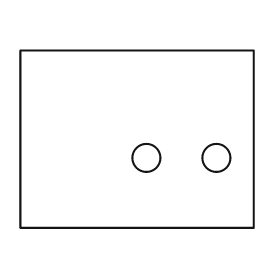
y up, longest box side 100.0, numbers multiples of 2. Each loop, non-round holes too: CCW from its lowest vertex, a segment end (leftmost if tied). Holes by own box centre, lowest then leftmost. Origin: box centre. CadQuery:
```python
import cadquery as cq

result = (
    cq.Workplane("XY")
    .moveTo(-50.0, -38.0)
    .lineTo(50.0, -38.0)
    .lineTo(50.0, 38.0)
    .lineTo(-50.0, 38.0)
    .close()
    .moveTo(4.0, -8.0)
    .circle(6.0)
    .moveTo(34.0, -8.0)
    .circle(6.0)
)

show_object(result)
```